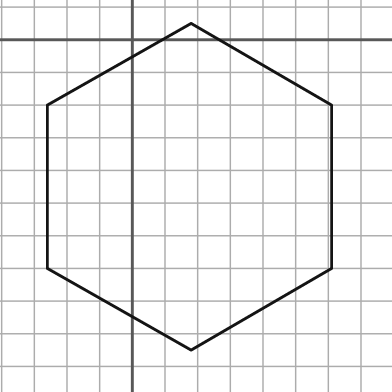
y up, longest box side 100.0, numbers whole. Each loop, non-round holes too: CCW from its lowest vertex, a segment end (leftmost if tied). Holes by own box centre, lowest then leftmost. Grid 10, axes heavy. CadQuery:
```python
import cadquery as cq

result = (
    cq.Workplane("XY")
    .moveTo(18.0, -95.0)
    .lineTo(61.0, -70.0)
    .lineTo(61.0, -20.0)
    .lineTo(18.0, 5.0)
    .lineTo(-26.0, -20.0)
    .lineTo(-26.0, -70.0)
    .close()
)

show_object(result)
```